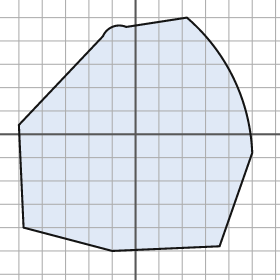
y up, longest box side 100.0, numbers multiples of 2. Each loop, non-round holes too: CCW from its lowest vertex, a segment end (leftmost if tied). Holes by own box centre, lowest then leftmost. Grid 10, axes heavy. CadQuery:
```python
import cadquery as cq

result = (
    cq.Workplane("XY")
    .moveTo(-10.0, -50.0)
    .lineTo(36.0, -48.0)
    .lineTo(50.0, -8.0)
    .threePointArc((42.0, 24.0), (22.0, 50.0))
    .lineTo(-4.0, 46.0)
    .threePointArc((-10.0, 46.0), (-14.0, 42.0))
    .lineTo(-50.0, 4.0)
    .lineTo(-48.0, -40.0)
    .close()
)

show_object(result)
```